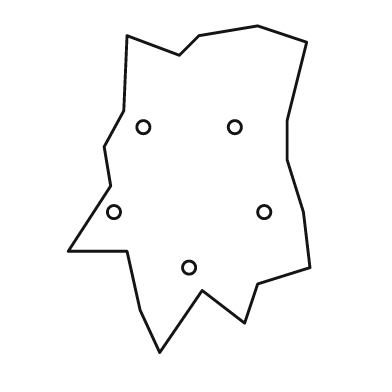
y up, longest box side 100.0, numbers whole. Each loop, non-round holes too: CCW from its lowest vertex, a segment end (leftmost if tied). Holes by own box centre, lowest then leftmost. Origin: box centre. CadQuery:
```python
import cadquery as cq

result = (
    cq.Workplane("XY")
    .moveTo(-9.0, -50.0)
    .lineTo(4.0, -31.0)
    .lineTo(17.0, -41.0)
    .lineTo(21.0, -29.0)
    .lineTo(37.0, -24.0)
    .lineTo(35.0, -7.0)
    .lineTo(30.0, 9.0)
    .lineTo(30.0, 21.0)
    .lineTo(36.0, 45.0)
    .lineTo(21.0, 50.0)
    .lineTo(3.0, 47.0)
    .lineTo(-3.0, 41.0)
    .lineTo(-19.0, 47.0)
    .lineTo(-20.0, 24.0)
    .lineTo(-26.0, 13.0)
    .lineTo(-24.0, 1.0)
    .lineTo(-37.0, -19.0)
    .lineTo(-19.0, -19.0)
    .lineTo(-15.0, -37.0)
    .close()
    .moveTo(0.0, -24.0)
    .circle(2.0)
    .moveTo(-23.0, -7.0)
    .circle(2.0)
    .moveTo(23.0, -7.0)
    .circle(2.0)
    .moveTo(-14.0, 19.0)
    .circle(2.0)
    .moveTo(14.0, 19.0)
    .circle(2.0)
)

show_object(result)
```